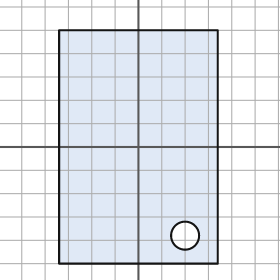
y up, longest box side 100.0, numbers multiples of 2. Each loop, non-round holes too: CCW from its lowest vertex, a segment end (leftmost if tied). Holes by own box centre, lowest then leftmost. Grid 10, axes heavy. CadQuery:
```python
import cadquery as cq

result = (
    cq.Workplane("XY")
    .moveTo(-34.0, -50.0)
    .lineTo(34.0, -50.0)
    .lineTo(34.0, 50.0)
    .lineTo(-34.0, 50.0)
    .close()
    .moveTo(20.0, -38.0)
    .circle(6.0)
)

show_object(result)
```